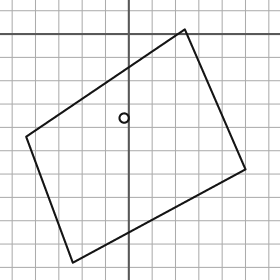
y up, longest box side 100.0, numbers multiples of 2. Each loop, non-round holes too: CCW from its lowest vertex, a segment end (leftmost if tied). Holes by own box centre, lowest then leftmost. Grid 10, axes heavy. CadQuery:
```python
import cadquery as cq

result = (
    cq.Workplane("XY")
    .moveTo(-24.0, -98.0)
    .lineTo(50.0, -58.0)
    .lineTo(24.0, 2.0)
    .lineTo(-44.0, -44.0)
    .close()
    .moveTo(-2.0, -36.0)
    .circle(2.0)
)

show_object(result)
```